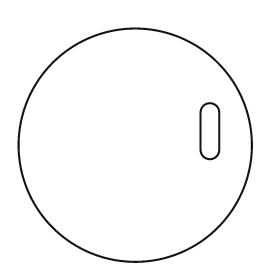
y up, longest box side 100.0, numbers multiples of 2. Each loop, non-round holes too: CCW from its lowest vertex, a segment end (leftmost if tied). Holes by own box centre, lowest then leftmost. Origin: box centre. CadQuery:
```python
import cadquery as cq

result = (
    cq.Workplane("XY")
    .moveTo(0.0, 0.0)
    .circle(50.0)
    .moveTo(28.0, -2.0)
    .threePointArc((32.0, -6.0), (36.0, -2.0))
    .lineTo(36.0, 14.0)
    .threePointArc((32.0, 18.0), (28.0, 14.0))
    .close()
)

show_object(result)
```